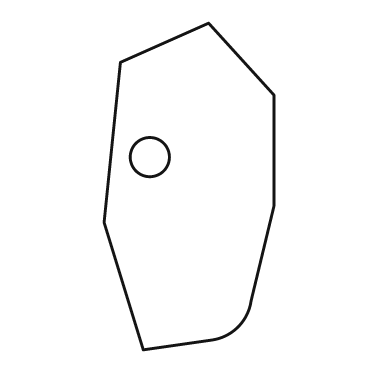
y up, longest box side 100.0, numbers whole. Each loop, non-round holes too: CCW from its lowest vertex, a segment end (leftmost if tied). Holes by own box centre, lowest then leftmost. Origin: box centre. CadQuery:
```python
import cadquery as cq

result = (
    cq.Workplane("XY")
    .moveTo(-14.0, -50.0)
    .lineTo(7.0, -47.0)
    .threePointArc((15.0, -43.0), (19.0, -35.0))
    .lineTo(26.0, -6.0)
    .lineTo(26.0, 28.0)
    .lineTo(6.0, 50.0)
    .lineTo(-21.0, 38.0)
    .lineTo(-26.0, -11.0)
    .close()
    .moveTo(-12.0, 9.0)
    .circle(6.0)
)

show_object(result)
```